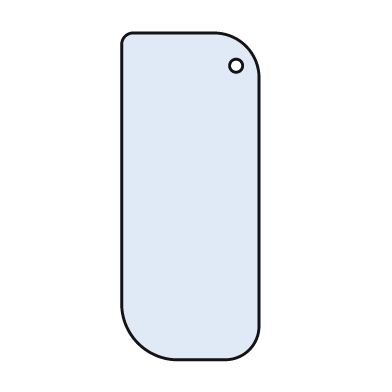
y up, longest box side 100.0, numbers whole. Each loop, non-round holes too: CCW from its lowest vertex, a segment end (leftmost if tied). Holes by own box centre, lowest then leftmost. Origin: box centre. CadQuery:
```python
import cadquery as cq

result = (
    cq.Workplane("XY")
    .moveTo(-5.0, -50.0)
    .lineTo(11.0, -50.0)
    .threePointArc((18.0, -47.0), (21.0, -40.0))
    .lineTo(21.0, 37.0)
    .threePointArc((17.0, 46.0), (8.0, 50.0))
    .lineTo(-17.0, 50.0)
    .threePointArc((-20.0, 49.0), (-21.0, 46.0))
    .lineTo(-21.0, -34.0)
    .threePointArc((-16.0, -45.0), (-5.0, -50.0))
    .close()
    .moveTo(14.0, 40.0)
    .circle(2.0)
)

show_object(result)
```